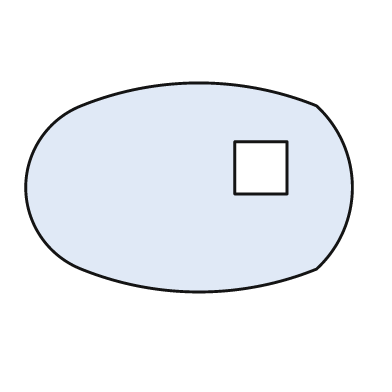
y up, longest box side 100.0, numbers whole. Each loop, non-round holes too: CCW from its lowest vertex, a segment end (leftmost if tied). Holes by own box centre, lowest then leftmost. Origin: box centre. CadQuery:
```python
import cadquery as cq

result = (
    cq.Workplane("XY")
    .moveTo(-33.0, -25.0)
    .threePointArc((3.0, -32.0), (39.0, -25.0))
    .threePointArc((50.0, 0.0), (39.0, 25.0))
    .threePointArc((3.0, 32.0), (-33.0, 25.0))
    .threePointArc((-50.0, 0.0), (-33.0, -25.0))
    .close()
    .moveTo(14.0, -2.0)
    .lineTo(30.0, -2.0)
    .lineTo(30.0, 14.0)
    .lineTo(14.0, 14.0)
    .close()
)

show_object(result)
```